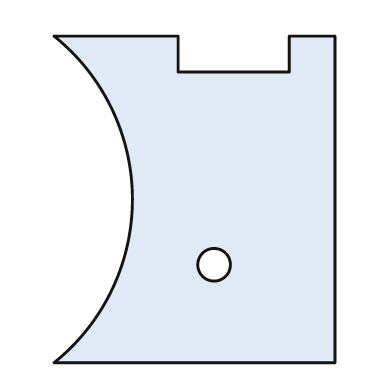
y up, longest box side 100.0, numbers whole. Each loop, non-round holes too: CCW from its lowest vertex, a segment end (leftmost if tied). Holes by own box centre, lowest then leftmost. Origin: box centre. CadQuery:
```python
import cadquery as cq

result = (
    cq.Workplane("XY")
    .moveTo(-43.0, -50.0)
    .lineTo(43.0, -50.0)
    .lineTo(43.0, 50.0)
    .lineTo(29.0, 50.0)
    .lineTo(29.0, 39.0)
    .lineTo(-5.0, 39.0)
    .lineTo(-5.0, 50.0)
    .lineTo(-43.0, 50.0)
    .threePointArc((-19.0, 0.0), (-43.0, -50.0))
    .close()
    .moveTo(6.0, -20.0)
    .circle(5.0)
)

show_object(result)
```